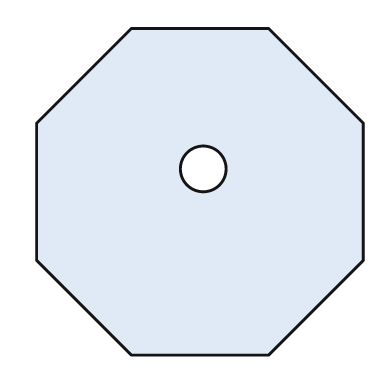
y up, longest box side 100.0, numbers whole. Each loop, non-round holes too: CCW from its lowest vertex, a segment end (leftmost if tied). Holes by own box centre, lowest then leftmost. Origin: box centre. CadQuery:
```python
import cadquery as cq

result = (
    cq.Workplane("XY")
    .moveTo(-21.0, -50.0)
    .lineTo(21.0, -50.0)
    .lineTo(50.0, -21.0)
    .lineTo(50.0, 21.0)
    .lineTo(21.0, 50.0)
    .lineTo(-21.0, 50.0)
    .lineTo(-50.0, 21.0)
    .lineTo(-50.0, -21.0)
    .close()
    .moveTo(1.0, 7.0)
    .circle(7.0)
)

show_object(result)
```